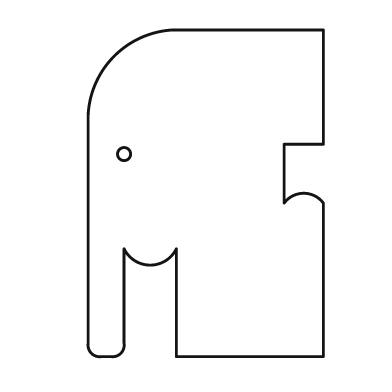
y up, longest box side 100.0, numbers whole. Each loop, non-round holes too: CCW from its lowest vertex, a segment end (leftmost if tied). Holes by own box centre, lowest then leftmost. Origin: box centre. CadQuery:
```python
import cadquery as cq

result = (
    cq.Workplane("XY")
    .moveTo(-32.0, -50.0)
    .lineTo(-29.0, -50.0)
    .threePointArc((-26.0, -49.0), (-25.0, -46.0))
    .lineTo(-25.0, -17.0)
    .threePointArc((-17.0, -22.0), (-9.0, -17.0))
    .lineTo(-9.0, -50.0)
    .lineTo(36.0, -50.0)
    .lineTo(36.0, -3.0)
    .threePointArc((30.0, 0.0), (24.0, -3.0))
    .lineTo(24.0, 15.0)
    .lineTo(36.0, 15.0)
    .lineTo(36.0, 50.0)
    .lineTo(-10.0, 50.0)
    .threePointArc((-28.0, 42.0), (-36.0, 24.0))
    .lineTo(-36.0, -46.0)
    .threePointArc((-35.0, -49.0), (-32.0, -50.0))
    .close()
    .moveTo(-25.0, 12.0)
    .circle(2.0)
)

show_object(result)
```